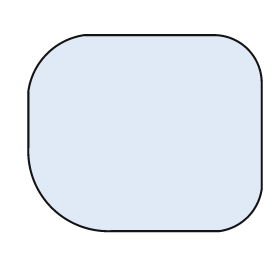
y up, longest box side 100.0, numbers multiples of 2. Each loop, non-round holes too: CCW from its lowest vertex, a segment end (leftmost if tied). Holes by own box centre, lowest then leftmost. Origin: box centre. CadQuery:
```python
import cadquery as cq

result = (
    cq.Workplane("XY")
    .moveTo(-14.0, -42.0)
    .lineTo(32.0, -42.0)
    .threePointArc((44.0, -36.0), (50.0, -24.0))
    .lineTo(50.0, 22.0)
    .threePointArc((44.0, 36.0), (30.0, 42.0))
    .lineTo(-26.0, 42.0)
    .threePointArc((-42.0, 34.0), (-50.0, 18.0))
    .lineTo(-50.0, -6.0)
    .threePointArc((-40.0, -32.0), (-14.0, -42.0))
    .close()
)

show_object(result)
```